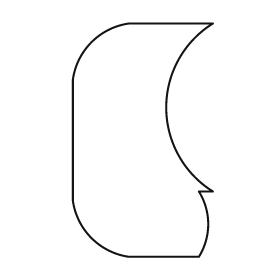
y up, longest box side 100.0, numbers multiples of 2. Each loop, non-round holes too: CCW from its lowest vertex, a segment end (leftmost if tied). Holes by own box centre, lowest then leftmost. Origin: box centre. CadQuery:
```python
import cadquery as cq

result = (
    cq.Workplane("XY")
    .moveTo(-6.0, -50.0)
    .lineTo(24.0, -50.0)
    .threePointArc((28.0, -36.0), (24.0, -22.0))
    .lineTo(30.0, -22.0)
    .threePointArc((10.0, 14.0), (30.0, 50.0))
    .lineTo(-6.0, 50.0)
    .threePointArc((-22.0, 42.0), (-30.0, 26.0))
    .lineTo(-30.0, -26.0)
    .threePointArc((-22.0, -42.0), (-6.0, -50.0))
    .close()
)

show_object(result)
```